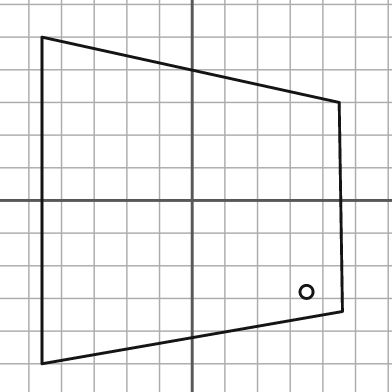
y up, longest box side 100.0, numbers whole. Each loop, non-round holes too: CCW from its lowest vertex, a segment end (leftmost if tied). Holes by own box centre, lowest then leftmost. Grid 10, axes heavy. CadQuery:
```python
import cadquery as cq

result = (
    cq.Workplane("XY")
    .moveTo(-46.0, -50.0)
    .lineTo(46.0, -34.0)
    .lineTo(45.0, 30.0)
    .lineTo(-46.0, 50.0)
    .close()
    .moveTo(35.0, -28.0)
    .circle(2.0)
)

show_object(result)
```